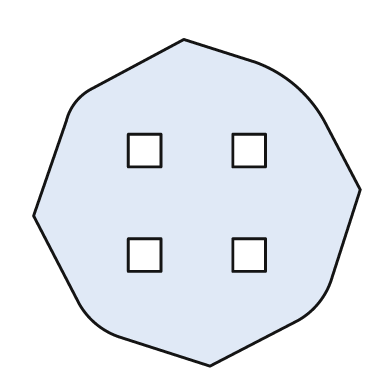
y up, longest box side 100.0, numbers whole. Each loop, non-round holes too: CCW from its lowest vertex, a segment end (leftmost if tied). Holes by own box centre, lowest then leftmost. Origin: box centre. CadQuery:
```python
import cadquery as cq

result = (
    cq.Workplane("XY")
    .moveTo(4.0, -50.0)
    .lineTo(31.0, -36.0)
    .threePointArc((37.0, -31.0), (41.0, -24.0))
    .lineTo(50.0, 4.0)
    .lineTo(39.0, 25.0)
    .threePointArc((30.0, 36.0), (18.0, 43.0))
    .lineTo(-4.0, 50.0)
    .lineTo(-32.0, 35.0)
    .threePointArc((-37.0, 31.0), (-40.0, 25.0))
    .lineTo(-50.0, -4.0)
    .lineTo(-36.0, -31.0)
    .threePointArc((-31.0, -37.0), (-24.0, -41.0))
    .close()
    .moveTo(-21.0, -21.0)
    .lineTo(-11.0, -21.0)
    .lineTo(-11.0, -11.0)
    .lineTo(-21.0, -11.0)
    .close()
    .moveTo(11.0, -21.0)
    .lineTo(21.0, -21.0)
    .lineTo(21.0, -11.0)
    .lineTo(11.0, -11.0)
    .close()
    .moveTo(-21.0, 11.0)
    .lineTo(-11.0, 11.0)
    .lineTo(-11.0, 21.0)
    .lineTo(-21.0, 21.0)
    .close()
    .moveTo(11.0, 11.0)
    .lineTo(21.0, 11.0)
    .lineTo(21.0, 21.0)
    .lineTo(11.0, 21.0)
    .close()
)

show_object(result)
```